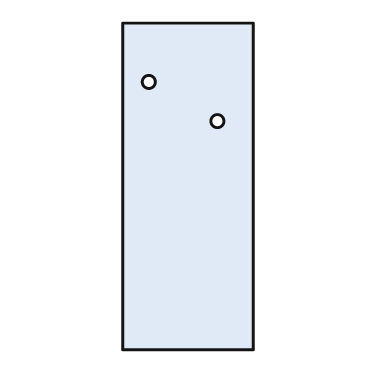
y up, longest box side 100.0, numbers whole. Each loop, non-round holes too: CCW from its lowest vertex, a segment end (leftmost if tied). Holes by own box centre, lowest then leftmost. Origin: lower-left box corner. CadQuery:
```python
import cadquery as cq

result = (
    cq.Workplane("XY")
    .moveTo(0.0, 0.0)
    .lineTo(40.0, 0.0)
    .lineTo(40.0, 100.0)
    .lineTo(0.0, 100.0)
    .close()
    .moveTo(29.0, 70.0)
    .circle(2.0)
    .moveTo(8.0, 82.0)
    .circle(2.0)
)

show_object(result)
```